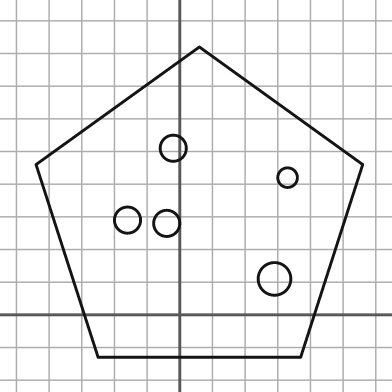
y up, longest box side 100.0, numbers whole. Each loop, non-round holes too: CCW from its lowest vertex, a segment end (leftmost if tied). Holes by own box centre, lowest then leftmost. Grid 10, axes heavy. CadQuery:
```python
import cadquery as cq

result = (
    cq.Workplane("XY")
    .moveTo(-25.0, -13.0)
    .lineTo(37.0, -13.0)
    .lineTo(56.0, 46.0)
    .lineTo(6.0, 82.0)
    .lineTo(-44.0, 46.0)
    .close()
    .moveTo(29.0, 11.0)
    .circle(5.0)
    .moveTo(-4.0, 28.0)
    .circle(4.0)
    .moveTo(-16.0, 29.0)
    .circle(4.0)
    .moveTo(33.0, 42.0)
    .circle(3.0)
    .moveTo(-2.0, 51.0)
    .circle(4.0)
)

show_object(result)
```